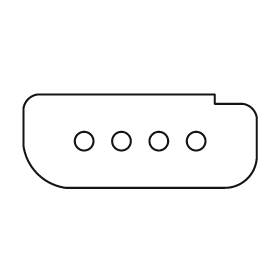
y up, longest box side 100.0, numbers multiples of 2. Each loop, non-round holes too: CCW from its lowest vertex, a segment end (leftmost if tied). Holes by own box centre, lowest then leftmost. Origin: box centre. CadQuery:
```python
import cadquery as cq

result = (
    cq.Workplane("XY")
    .moveTo(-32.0, -20.0)
    .lineTo(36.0, -20.0)
    .threePointArc((46.0, -16.0), (50.0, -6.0))
    .lineTo(50.0, 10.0)
    .threePointArc((48.0, 14.0), (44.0, 16.0))
    .lineTo(32.0, 16.0)
    .lineTo(32.0, 20.0)
    .lineTo(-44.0, 20.0)
    .threePointArc((-48.0, 18.0), (-50.0, 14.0))
    .lineTo(-50.0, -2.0)
    .threePointArc((-44.0, -14.0), (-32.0, -20.0))
    .close()
    .moveTo(-24.0, 0.0)
    .circle(4.0)
    .moveTo(-8.0, 0.0)
    .circle(4.0)
    .moveTo(8.0, 0.0)
    .circle(4.0)
    .moveTo(24.0, 0.0)
    .circle(4.0)
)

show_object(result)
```